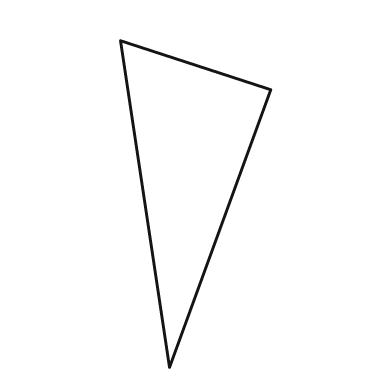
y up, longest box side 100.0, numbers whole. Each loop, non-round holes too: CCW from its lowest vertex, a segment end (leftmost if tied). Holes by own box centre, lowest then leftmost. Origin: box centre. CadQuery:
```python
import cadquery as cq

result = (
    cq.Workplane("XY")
    .moveTo(-8.0, -50.0)
    .lineTo(23.0, 35.0)
    .lineTo(-23.0, 50.0)
    .close()
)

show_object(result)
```